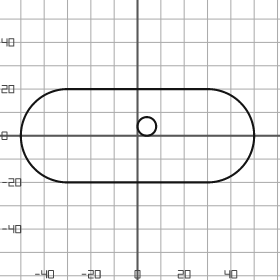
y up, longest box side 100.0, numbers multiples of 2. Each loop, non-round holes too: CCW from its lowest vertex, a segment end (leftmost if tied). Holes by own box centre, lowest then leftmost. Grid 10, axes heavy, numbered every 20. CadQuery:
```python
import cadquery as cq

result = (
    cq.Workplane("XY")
    .moveTo(-30.0, -20.0)
    .lineTo(30.0, -20.0)
    .threePointArc((50.0, 0.0), (30.0, 20.0))
    .lineTo(-30.0, 20.0)
    .threePointArc((-50.0, 0.0), (-30.0, -20.0))
    .close()
    .moveTo(4.0, 4.0)
    .circle(4.0)
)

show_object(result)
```